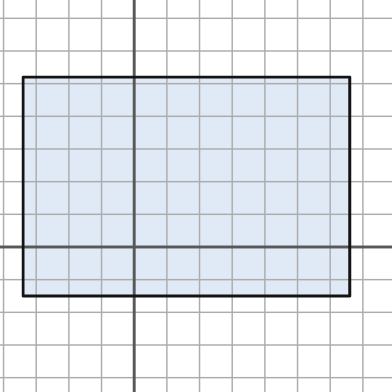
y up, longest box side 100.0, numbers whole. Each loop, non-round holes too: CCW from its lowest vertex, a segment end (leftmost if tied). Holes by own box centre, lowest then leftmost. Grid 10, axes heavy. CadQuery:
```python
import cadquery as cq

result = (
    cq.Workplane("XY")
    .moveTo(-34.0, -15.0)
    .lineTo(66.0, -15.0)
    .lineTo(66.0, 52.0)
    .lineTo(-34.0, 52.0)
    .close()
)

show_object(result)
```